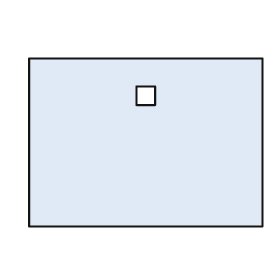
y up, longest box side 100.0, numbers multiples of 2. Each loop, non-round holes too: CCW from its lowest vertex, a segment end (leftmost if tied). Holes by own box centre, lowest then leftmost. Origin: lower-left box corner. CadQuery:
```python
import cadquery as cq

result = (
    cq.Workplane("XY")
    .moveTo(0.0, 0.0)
    .lineTo(100.0, 0.0)
    .lineTo(100.0, 72.0)
    .lineTo(0.0, 72.0)
    .close()
    .moveTo(46.0, 52.0)
    .lineTo(54.0, 52.0)
    .lineTo(54.0, 60.0)
    .lineTo(46.0, 60.0)
    .close()
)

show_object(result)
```